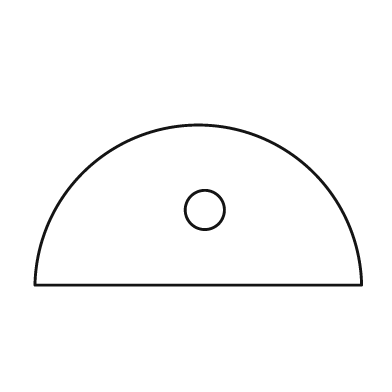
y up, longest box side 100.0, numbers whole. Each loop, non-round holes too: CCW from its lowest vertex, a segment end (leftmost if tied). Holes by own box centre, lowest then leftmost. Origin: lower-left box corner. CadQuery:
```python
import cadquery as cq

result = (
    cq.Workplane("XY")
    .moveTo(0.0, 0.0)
    .lineTo(100.0, 0.0)
    .threePointArc((50.0, 49.0), (0.0, 0.0))
    .close()
    .moveTo(52.0, 23.0)
    .circle(6.0)
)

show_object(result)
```